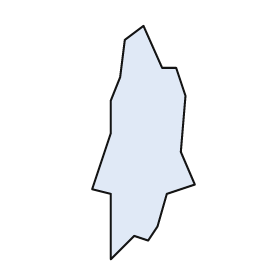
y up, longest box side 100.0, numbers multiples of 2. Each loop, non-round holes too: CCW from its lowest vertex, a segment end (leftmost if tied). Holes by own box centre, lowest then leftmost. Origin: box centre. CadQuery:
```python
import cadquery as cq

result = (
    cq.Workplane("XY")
    .moveTo(-14.0, -50.0)
    .lineTo(-4.0, -40.0)
    .lineTo(2.0, -42.0)
    .lineTo(6.0, -36.0)
    .lineTo(10.0, -22.0)
    .lineTo(22.0, -18.0)
    .lineTo(16.0, -4.0)
    .lineTo(18.0, 20.0)
    .lineTo(14.0, 32.0)
    .lineTo(8.0, 32.0)
    .lineTo(0.0, 50.0)
    .lineTo(-8.0, 44.0)
    .lineTo(-10.0, 28.0)
    .lineTo(-14.0, 18.0)
    .lineTo(-14.0, 4.0)
    .lineTo(-22.0, -20.0)
    .lineTo(-14.0, -22.0)
    .close()
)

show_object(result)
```